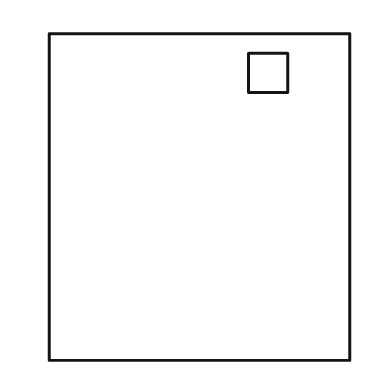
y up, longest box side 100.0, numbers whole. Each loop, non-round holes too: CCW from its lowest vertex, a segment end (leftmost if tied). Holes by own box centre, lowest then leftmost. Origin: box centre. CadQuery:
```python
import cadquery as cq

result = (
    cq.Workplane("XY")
    .moveTo(-46.0, -50.0)
    .lineTo(46.0, -50.0)
    .lineTo(46.0, 50.0)
    .lineTo(-46.0, 50.0)
    .close()
    .moveTo(15.0, 32.0)
    .lineTo(27.0, 32.0)
    .lineTo(27.0, 44.0)
    .lineTo(15.0, 44.0)
    .close()
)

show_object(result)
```